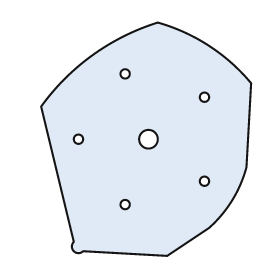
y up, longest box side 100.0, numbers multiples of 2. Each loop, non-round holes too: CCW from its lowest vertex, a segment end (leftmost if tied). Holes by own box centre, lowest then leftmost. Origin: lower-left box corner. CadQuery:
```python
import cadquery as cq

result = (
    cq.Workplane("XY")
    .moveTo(54.0, 0.0)
    .lineTo(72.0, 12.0)
    .threePointArc((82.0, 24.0), (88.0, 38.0))
    .lineTo(90.0, 74.0)
    .threePointArc((72.0, 90.0), (50.0, 100.0))
    .threePointArc((22.0, 86.0), (0.0, 64.0))
    .lineTo(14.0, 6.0)
    .threePointArc((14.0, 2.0), (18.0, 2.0))
    .close()
    .moveTo(36.0, 22.0)
    .circle(2.0)
    .moveTo(70.0, 32.0)
    .circle(2.0)
    .moveTo(16.0, 50.0)
    .circle(2.0)
    .moveTo(46.0, 50.0)
    .circle(4.0)
    .moveTo(70.0, 68.0)
    .circle(2.0)
    .moveTo(36.0, 78.0)
    .circle(2.0)
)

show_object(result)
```